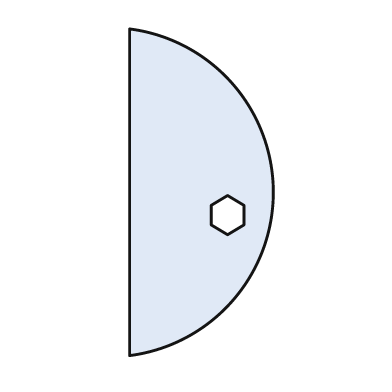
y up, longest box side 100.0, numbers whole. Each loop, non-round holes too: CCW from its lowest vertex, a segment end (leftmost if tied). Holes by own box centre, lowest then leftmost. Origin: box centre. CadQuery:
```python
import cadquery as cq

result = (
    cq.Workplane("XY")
    .moveTo(-22.0, -50.0)
    .threePointArc((22.0, 0.0), (-22.0, 50.0))
    .close()
    .moveTo(8.0, -13.0)
    .lineTo(13.0, -10.0)
    .lineTo(13.0, -4.0)
    .lineTo(8.0, -1.0)
    .lineTo(3.0, -4.0)
    .lineTo(3.0, -10.0)
    .close()
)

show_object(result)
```